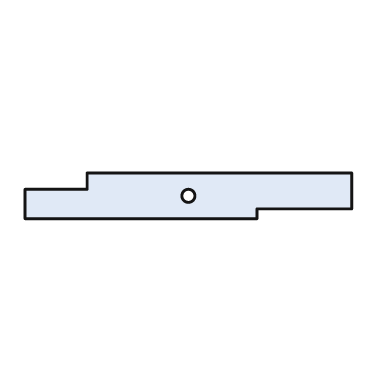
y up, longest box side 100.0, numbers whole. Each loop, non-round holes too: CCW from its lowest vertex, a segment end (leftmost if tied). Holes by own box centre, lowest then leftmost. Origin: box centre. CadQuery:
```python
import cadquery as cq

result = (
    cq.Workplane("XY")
    .moveTo(-50.0, -7.0)
    .lineTo(21.0, -7.0)
    .lineTo(21.0, -4.0)
    .lineTo(50.0, -4.0)
    .lineTo(50.0, 7.0)
    .lineTo(-31.0, 7.0)
    .lineTo(-31.0, 2.0)
    .lineTo(-50.0, 2.0)
    .close()
    .moveTo(0.0, 0.0)
    .circle(2.0)
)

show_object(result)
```